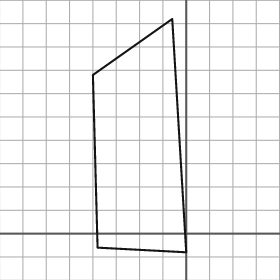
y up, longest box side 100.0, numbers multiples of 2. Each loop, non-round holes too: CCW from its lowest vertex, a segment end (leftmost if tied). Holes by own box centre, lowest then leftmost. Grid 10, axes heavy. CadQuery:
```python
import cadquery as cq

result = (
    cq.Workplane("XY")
    .moveTo(0.0, -8.0)
    .lineTo(-6.0, 92.0)
    .lineTo(-40.0, 68.0)
    .lineTo(-38.0, -6.0)
    .close()
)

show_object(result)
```